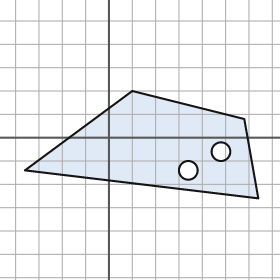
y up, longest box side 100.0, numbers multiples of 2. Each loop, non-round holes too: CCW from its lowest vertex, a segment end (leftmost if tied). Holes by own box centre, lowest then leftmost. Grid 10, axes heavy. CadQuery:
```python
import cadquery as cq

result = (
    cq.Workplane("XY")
    .moveTo(64.0, -26.0)
    .lineTo(58.0, 8.0)
    .lineTo(10.0, 20.0)
    .lineTo(-36.0, -14.0)
    .close()
    .moveTo(34.0, -14.0)
    .circle(4.0)
    .moveTo(48.0, -6.0)
    .circle(4.0)
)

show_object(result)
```